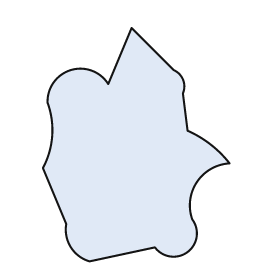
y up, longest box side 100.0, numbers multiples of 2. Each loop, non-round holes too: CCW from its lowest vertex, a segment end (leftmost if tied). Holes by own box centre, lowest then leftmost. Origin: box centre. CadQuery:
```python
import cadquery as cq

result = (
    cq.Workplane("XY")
    .moveTo(-20.0, -50.0)
    .lineTo(8.0, -44.0)
    .threePointArc((22.0, -46.0), (24.0, -32.0))
    .threePointArc((26.0, -16.0), (40.0, -8.0))
    .threePointArc((32.0, 0.0), (22.0, 6.0))
    .lineTo(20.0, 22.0)
    .threePointArc((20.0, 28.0), (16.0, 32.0))
    .lineTo(-2.0, 50.0)
    .lineTo(-12.0, 26.0)
    .threePointArc((-28.0, 32.0), (-38.0, 18.0))
    .threePointArc((-36.0, 4.0), (-40.0, -10.0))
    .lineTo(-30.0, -34.0)
    .threePointArc((-28.0, -44.0), (-20.0, -50.0))
    .close()
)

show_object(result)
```